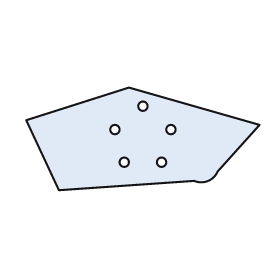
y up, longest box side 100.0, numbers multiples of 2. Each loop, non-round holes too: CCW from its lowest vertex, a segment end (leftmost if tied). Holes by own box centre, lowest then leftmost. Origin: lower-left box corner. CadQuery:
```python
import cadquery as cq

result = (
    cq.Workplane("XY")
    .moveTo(14.0, 0.0)
    .lineTo(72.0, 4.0)
    .threePointArc((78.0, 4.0), (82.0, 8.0))
    .lineTo(100.0, 28.0)
    .lineTo(44.0, 44.0)
    .lineTo(0.0, 30.0)
    .close()
    .moveTo(42.0, 12.0)
    .circle(2.0)
    .moveTo(58.0, 12.0)
    .circle(2.0)
    .moveTo(38.0, 26.0)
    .circle(2.0)
    .moveTo(62.0, 26.0)
    .circle(2.0)
    .moveTo(50.0, 36.0)
    .circle(2.0)
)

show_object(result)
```